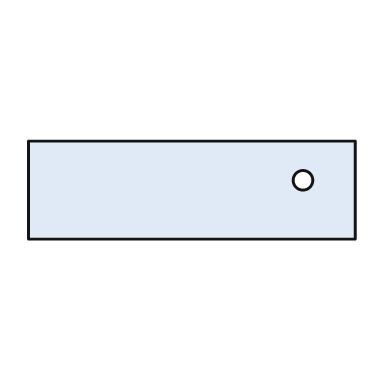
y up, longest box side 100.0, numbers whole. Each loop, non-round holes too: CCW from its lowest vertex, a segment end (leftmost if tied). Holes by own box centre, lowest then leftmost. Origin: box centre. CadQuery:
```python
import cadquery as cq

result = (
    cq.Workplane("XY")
    .moveTo(-50.0, -15.0)
    .lineTo(50.0, -15.0)
    .lineTo(50.0, 15.0)
    .lineTo(-50.0, 15.0)
    .close()
    .moveTo(34.0, 3.0)
    .circle(3.0)
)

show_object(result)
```